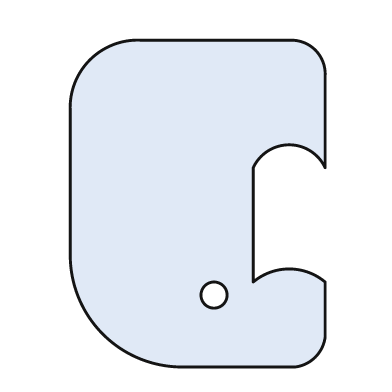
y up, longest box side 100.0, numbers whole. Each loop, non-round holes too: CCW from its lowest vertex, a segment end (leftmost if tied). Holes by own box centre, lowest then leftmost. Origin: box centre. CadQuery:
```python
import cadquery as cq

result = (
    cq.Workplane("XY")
    .moveTo(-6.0, -50.0)
    .lineTo(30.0, -50.0)
    .threePointArc((36.0, -47.0), (39.0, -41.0))
    .lineTo(39.0, -24.0)
    .threePointArc((28.0, -20.0), (17.0, -24.0))
    .lineTo(17.0, 11.0)
    .threePointArc((28.0, 18.0), (39.0, 11.0))
    .lineTo(39.0, 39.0)
    .threePointArc((36.0, 47.0), (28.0, 50.0))
    .lineTo(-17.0, 50.0)
    .threePointArc((-33.0, 44.0), (-39.0, 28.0))
    .lineTo(-39.0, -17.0)
    .threePointArc((-29.0, -40.0), (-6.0, -50.0))
    .close()
    .moveTo(5.0, -28.0)
    .circle(4.0)
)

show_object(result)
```